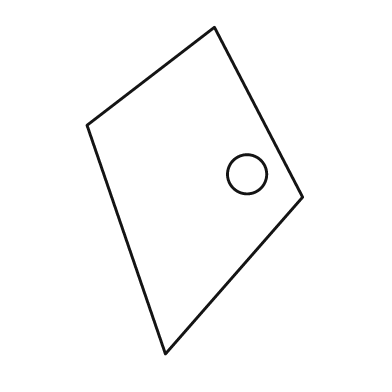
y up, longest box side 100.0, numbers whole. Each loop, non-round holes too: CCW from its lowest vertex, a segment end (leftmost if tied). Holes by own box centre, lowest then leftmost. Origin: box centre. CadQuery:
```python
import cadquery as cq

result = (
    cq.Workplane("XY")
    .moveTo(-9.0, -50.0)
    .lineTo(33.0, -2.0)
    .lineTo(6.0, 50.0)
    .lineTo(-33.0, 20.0)
    .close()
    .moveTo(16.0, 5.0)
    .circle(6.0)
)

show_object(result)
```